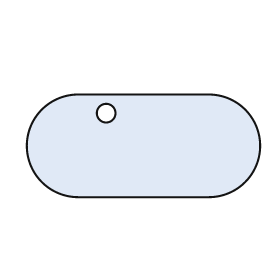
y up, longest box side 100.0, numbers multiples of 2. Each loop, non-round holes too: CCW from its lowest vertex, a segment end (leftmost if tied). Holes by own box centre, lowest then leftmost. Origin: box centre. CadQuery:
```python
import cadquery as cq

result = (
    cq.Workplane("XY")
    .moveTo(-28.0, -22.0)
    .lineTo(28.0, -22.0)
    .threePointArc((50.0, 0.0), (28.0, 22.0))
    .lineTo(-28.0, 22.0)
    .threePointArc((-50.0, 0.0), (-28.0, -22.0))
    .close()
    .moveTo(-16.0, 14.0)
    .circle(4.0)
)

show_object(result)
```